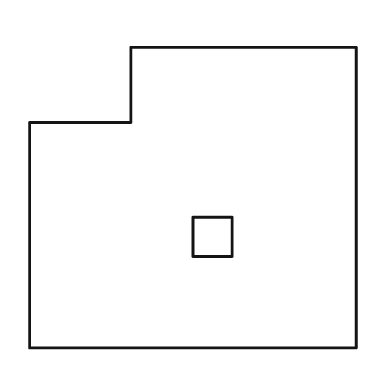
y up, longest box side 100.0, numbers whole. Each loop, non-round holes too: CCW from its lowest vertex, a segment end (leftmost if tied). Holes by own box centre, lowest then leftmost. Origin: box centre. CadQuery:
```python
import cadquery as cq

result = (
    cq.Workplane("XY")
    .moveTo(-50.0, -46.0)
    .lineTo(50.0, -46.0)
    .lineTo(50.0, 46.0)
    .lineTo(-19.0, 46.0)
    .lineTo(-19.0, 23.0)
    .lineTo(-50.0, 23.0)
    .close()
    .moveTo(0.0, -18.0)
    .lineTo(12.0, -18.0)
    .lineTo(12.0, -6.0)
    .lineTo(0.0, -6.0)
    .close()
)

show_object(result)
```